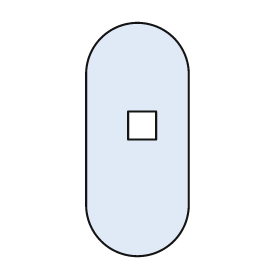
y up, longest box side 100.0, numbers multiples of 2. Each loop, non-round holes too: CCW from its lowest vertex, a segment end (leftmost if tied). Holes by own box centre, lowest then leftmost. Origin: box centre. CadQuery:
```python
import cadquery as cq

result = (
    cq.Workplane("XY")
    .moveTo(-22.0, -28.0)
    .threePointArc((0.0, -50.0), (22.0, -28.0))
    .lineTo(22.0, 28.0)
    .threePointArc((0.0, 50.0), (-22.0, 28.0))
    .close()
    .moveTo(-4.0, 0.0)
    .lineTo(8.0, 0.0)
    .lineTo(8.0, 12.0)
    .lineTo(-4.0, 12.0)
    .close()
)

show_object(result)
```